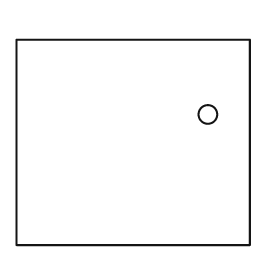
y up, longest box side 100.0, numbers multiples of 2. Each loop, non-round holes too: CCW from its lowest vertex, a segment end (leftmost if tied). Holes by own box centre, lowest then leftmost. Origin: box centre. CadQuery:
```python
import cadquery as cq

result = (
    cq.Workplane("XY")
    .moveTo(-50.0, -44.0)
    .lineTo(50.0, -44.0)
    .lineTo(50.0, 44.0)
    .lineTo(-50.0, 44.0)
    .close()
    .moveTo(32.0, 12.0)
    .circle(4.0)
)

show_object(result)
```